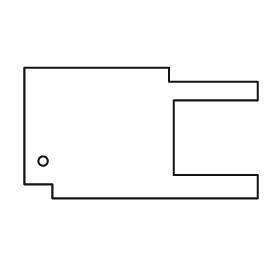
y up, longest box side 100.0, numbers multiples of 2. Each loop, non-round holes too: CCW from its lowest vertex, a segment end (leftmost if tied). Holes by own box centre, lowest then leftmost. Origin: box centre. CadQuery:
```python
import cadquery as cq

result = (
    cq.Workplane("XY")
    .moveTo(-38.0, -28.0)
    .lineTo(50.0, -28.0)
    .lineTo(50.0, -18.0)
    .lineTo(14.0, -18.0)
    .lineTo(14.0, 14.0)
    .lineTo(50.0, 14.0)
    .lineTo(50.0, 22.0)
    .lineTo(12.0, 22.0)
    .lineTo(12.0, 28.0)
    .lineTo(-50.0, 28.0)
    .lineTo(-50.0, -22.0)
    .lineTo(-38.0, -22.0)
    .close()
    .moveTo(-42.0, -12.0)
    .circle(2.0)
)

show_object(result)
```